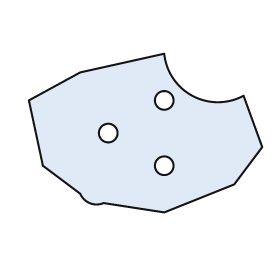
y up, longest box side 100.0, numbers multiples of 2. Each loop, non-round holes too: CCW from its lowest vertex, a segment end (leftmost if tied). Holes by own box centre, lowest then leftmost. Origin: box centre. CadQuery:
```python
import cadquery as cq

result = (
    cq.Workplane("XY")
    .moveTo(8.0, -34.0)
    .lineTo(38.0, -22.0)
    .lineTo(50.0, -6.0)
    .lineTo(42.0, 16.0)
    .threePointArc((20.0, 16.0), (8.0, 34.0))
    .lineTo(-28.0, 26.0)
    .lineTo(-50.0, 14.0)
    .lineTo(-44.0, -14.0)
    .lineTo(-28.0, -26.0)
    .threePointArc((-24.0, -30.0), (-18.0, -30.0))
    .close()
    .moveTo(8.0, -14.0)
    .circle(4.0)
    .moveTo(-16.0, 0.0)
    .circle(4.0)
    .moveTo(8.0, 14.0)
    .circle(4.0)
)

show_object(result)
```